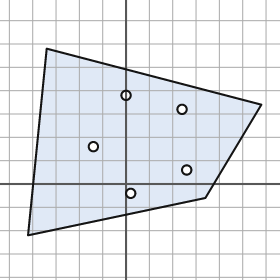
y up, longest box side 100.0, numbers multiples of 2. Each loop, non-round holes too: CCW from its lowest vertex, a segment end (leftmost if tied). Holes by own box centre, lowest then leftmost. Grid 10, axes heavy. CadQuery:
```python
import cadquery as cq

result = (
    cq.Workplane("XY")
    .moveTo(-42.0, -22.0)
    .lineTo(34.0, -6.0)
    .lineTo(58.0, 34.0)
    .lineTo(-34.0, 58.0)
    .close()
    .moveTo(2.0, -4.0)
    .circle(2.0)
    .moveTo(26.0, 6.0)
    .circle(2.0)
    .moveTo(-14.0, 16.0)
    .circle(2.0)
    .moveTo(24.0, 32.0)
    .circle(2.0)
    .moveTo(0.0, 38.0)
    .circle(2.0)
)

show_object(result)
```